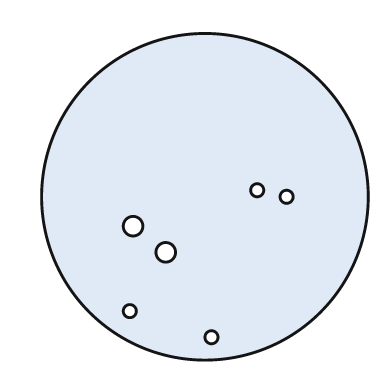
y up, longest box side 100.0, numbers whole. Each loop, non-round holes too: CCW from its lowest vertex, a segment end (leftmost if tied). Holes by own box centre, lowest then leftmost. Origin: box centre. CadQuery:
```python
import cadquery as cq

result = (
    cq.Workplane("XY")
    .moveTo(0.0, 0.0)
    .circle(50.0)
    .moveTo(2.0, -43.0)
    .circle(2.0)
    .moveTo(-23.0, -35.0)
    .circle(2.0)
    .moveTo(-12.0, -17.0)
    .circle(3.0)
    .moveTo(-22.0, -9.0)
    .circle(3.0)
    .moveTo(25.0, 0.0)
    .circle(2.0)
    .moveTo(16.0, 2.0)
    .circle(2.0)
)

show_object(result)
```